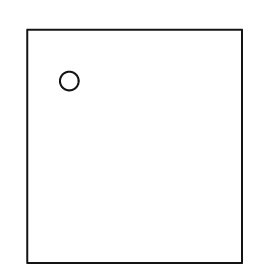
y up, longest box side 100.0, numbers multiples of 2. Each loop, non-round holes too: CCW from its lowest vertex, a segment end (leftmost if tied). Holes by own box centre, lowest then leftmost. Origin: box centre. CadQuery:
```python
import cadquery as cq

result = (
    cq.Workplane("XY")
    .moveTo(-46.0, -50.0)
    .lineTo(46.0, -50.0)
    .lineTo(46.0, 50.0)
    .lineTo(-46.0, 50.0)
    .close()
    .moveTo(-28.0, 28.0)
    .circle(4.0)
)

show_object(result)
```